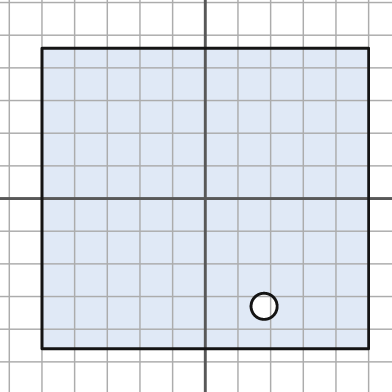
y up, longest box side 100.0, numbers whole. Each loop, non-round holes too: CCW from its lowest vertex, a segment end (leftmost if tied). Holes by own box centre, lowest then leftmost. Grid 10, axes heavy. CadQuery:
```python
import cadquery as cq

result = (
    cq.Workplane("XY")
    .moveTo(-50.0, -46.0)
    .lineTo(50.0, -46.0)
    .lineTo(50.0, 46.0)
    .lineTo(-50.0, 46.0)
    .close()
    .moveTo(18.0, -33.0)
    .circle(4.0)
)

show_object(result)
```